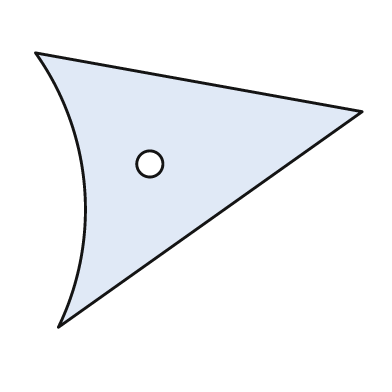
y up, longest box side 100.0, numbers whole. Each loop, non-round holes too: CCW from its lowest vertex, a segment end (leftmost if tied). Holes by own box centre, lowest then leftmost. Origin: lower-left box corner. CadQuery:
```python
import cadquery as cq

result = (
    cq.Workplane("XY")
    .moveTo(7.0, 0.0)
    .lineTo(100.0, 66.0)
    .lineTo(0.0, 84.0)
    .threePointArc((15.0, 43.0), (7.0, 0.0))
    .close()
    .moveTo(35.0, 50.0)
    .circle(4.0)
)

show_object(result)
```